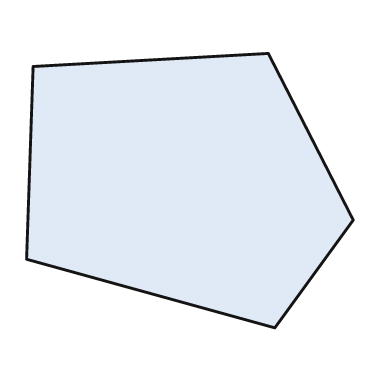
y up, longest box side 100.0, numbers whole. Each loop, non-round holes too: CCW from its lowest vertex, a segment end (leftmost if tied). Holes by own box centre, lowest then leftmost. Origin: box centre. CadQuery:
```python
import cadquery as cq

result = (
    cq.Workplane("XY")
    .moveTo(26.0, -42.0)
    .lineTo(50.0, -9.0)
    .lineTo(24.0, 42.0)
    .lineTo(-48.0, 38.0)
    .lineTo(-50.0, -21.0)
    .close()
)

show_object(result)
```